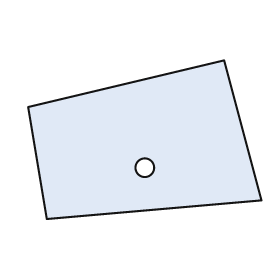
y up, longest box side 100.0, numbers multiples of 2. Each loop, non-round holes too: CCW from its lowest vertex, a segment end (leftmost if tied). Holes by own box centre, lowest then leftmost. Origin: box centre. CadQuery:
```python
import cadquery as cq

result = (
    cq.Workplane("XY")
    .moveTo(-42.0, -34.0)
    .lineTo(50.0, -26.0)
    .lineTo(34.0, 34.0)
    .lineTo(-50.0, 14.0)
    .close()
    .moveTo(0.0, -12.0)
    .circle(4.0)
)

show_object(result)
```